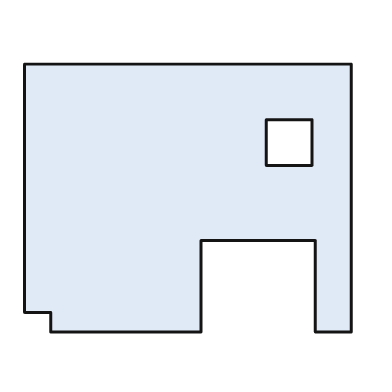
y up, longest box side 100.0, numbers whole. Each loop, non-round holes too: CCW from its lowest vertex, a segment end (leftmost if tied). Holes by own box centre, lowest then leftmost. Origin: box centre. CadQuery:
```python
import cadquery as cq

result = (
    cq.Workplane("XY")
    .moveTo(-42.0, -41.0)
    .lineTo(4.0, -41.0)
    .lineTo(4.0, -13.0)
    .lineTo(39.0, -13.0)
    .lineTo(39.0, -41.0)
    .lineTo(50.0, -41.0)
    .lineTo(50.0, 41.0)
    .lineTo(-50.0, 41.0)
    .lineTo(-50.0, -35.0)
    .lineTo(-42.0, -35.0)
    .close()
    .moveTo(24.0, 10.0)
    .lineTo(38.0, 10.0)
    .lineTo(38.0, 24.0)
    .lineTo(24.0, 24.0)
    .close()
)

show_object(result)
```